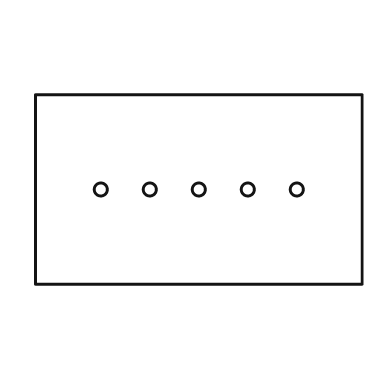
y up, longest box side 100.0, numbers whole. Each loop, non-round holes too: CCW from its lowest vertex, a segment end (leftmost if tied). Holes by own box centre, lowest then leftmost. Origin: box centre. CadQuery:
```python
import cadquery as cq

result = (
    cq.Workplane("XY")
    .moveTo(-50.0, -29.0)
    .lineTo(50.0, -29.0)
    .lineTo(50.0, 29.0)
    .lineTo(-50.0, 29.0)
    .close()
    .moveTo(-30.0, 0.0)
    .circle(2.0)
    .moveTo(-15.0, 0.0)
    .circle(2.0)
    .moveTo(0.0, 0.0)
    .circle(2.0)
    .moveTo(15.0, 0.0)
    .circle(2.0)
    .moveTo(30.0, 0.0)
    .circle(2.0)
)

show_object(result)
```